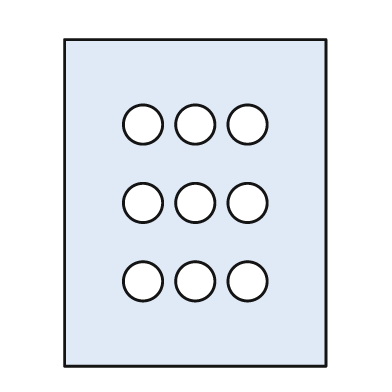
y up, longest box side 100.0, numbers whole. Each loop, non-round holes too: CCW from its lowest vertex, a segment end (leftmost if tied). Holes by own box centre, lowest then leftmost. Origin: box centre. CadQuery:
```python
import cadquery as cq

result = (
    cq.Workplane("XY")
    .moveTo(-40.0, -50.0)
    .lineTo(40.0, -50.0)
    .lineTo(40.0, 50.0)
    .lineTo(-40.0, 50.0)
    .close()
    .moveTo(-16.0, -24.0)
    .circle(6.0)
    .moveTo(0.0, -24.0)
    .circle(6.0)
    .moveTo(16.0, -24.0)
    .circle(6.0)
    .moveTo(-16.0, 0.0)
    .circle(6.0)
    .moveTo(0.0, 0.0)
    .circle(6.0)
    .moveTo(16.0, 0.0)
    .circle(6.0)
    .moveTo(-16.0, 24.0)
    .circle(6.0)
    .moveTo(0.0, 24.0)
    .circle(6.0)
    .moveTo(16.0, 24.0)
    .circle(6.0)
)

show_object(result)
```